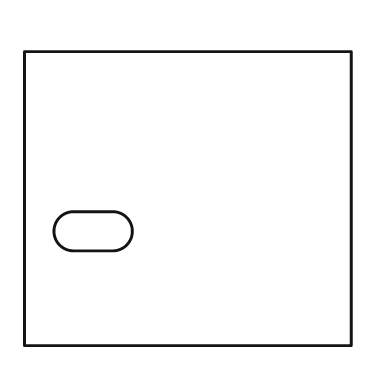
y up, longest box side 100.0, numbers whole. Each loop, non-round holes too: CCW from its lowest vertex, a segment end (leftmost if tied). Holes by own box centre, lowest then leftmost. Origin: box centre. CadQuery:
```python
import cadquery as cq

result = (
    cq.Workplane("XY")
    .moveTo(-50.0, -45.0)
    .lineTo(50.0, -45.0)
    .lineTo(50.0, 45.0)
    .lineTo(-50.0, 45.0)
    .close()
    .moveTo(-35.0, -16.0)
    .lineTo(-23.0, -16.0)
    .threePointArc((-17.0, -10.0), (-23.0, -4.0))
    .lineTo(-35.0, -4.0)
    .threePointArc((-41.0, -10.0), (-35.0, -16.0))
    .close()
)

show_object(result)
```